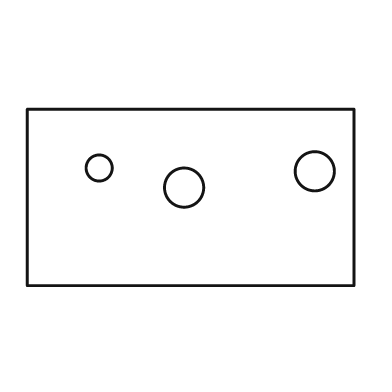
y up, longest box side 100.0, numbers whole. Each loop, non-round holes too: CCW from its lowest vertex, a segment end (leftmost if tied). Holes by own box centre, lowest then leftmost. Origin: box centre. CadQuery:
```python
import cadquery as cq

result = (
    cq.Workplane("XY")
    .moveTo(-50.0, -27.0)
    .lineTo(50.0, -27.0)
    .lineTo(50.0, 27.0)
    .lineTo(-50.0, 27.0)
    .close()
    .moveTo(-2.0, 3.0)
    .circle(6.0)
    .moveTo(38.0, 8.0)
    .circle(6.0)
    .moveTo(-28.0, 9.0)
    .circle(4.0)
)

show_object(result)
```